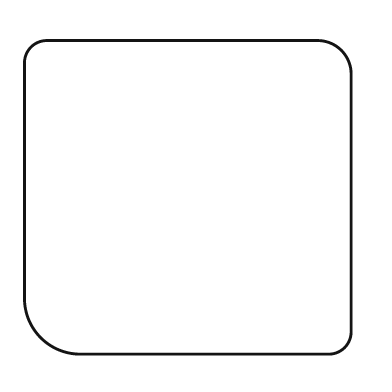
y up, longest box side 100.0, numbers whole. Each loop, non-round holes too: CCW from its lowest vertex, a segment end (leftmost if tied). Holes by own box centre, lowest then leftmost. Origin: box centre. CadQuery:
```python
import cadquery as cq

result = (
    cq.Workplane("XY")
    .moveTo(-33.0, -48.0)
    .lineTo(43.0, -48.0)
    .threePointArc((48.0, -46.0), (50.0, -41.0))
    .lineTo(50.0, 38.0)
    .threePointArc((47.0, 45.0), (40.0, 48.0))
    .lineTo(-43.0, 48.0)
    .threePointArc((-48.0, 46.0), (-50.0, 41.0))
    .lineTo(-50.0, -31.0)
    .threePointArc((-45.0, -43.0), (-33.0, -48.0))
    .close()
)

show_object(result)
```